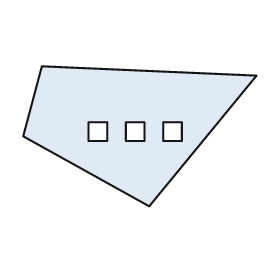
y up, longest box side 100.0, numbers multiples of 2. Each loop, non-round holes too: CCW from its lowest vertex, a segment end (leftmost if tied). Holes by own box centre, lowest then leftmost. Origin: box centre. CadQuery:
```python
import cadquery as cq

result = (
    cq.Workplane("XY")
    .moveTo(4.0, -30.0)
    .lineTo(50.0, 26.0)
    .lineTo(-42.0, 30.0)
    .lineTo(-50.0, 0.0)
    .close()
    .moveTo(-22.0, -2.0)
    .lineTo(-14.0, -2.0)
    .lineTo(-14.0, 6.0)
    .lineTo(-22.0, 6.0)
    .close()
    .moveTo(-6.0, -2.0)
    .lineTo(2.0, -2.0)
    .lineTo(2.0, 6.0)
    .lineTo(-6.0, 6.0)
    .close()
    .moveTo(10.0, -2.0)
    .lineTo(18.0, -2.0)
    .lineTo(18.0, 6.0)
    .lineTo(10.0, 6.0)
    .close()
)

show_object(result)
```